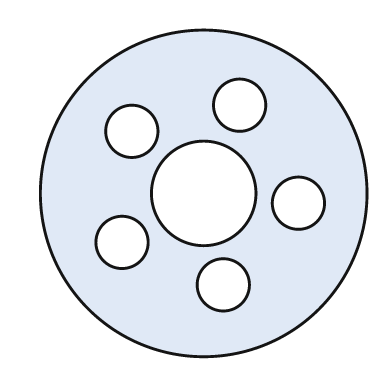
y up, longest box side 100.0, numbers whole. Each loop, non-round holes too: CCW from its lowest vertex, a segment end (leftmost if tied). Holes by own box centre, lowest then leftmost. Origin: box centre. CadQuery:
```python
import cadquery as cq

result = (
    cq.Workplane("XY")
    .moveTo(0.0, 0.0)
    .circle(50.0)
    .moveTo(6.0, -28.0)
    .circle(8.0)
    .moveTo(-25.0, -15.0)
    .circle(8.0)
    .moveTo(29.0, -3.0)
    .circle(8.0)
    .moveTo(0.0, 0.0)
    .circle(16.0)
    .moveTo(-22.0, 19.0)
    .circle(8.0)
    .moveTo(11.0, 27.0)
    .circle(8.0)
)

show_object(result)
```